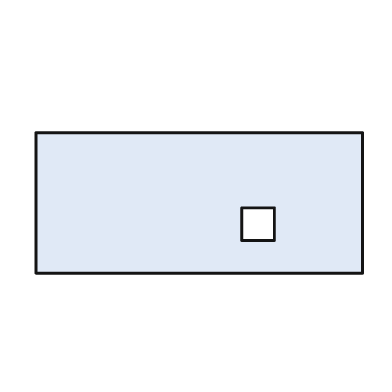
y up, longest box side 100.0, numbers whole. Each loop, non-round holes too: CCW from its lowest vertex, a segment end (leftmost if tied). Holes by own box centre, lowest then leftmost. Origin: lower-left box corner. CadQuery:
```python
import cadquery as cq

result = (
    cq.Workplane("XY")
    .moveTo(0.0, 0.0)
    .lineTo(100.0, 0.0)
    .lineTo(100.0, 43.0)
    .lineTo(0.0, 43.0)
    .close()
    .moveTo(63.0, 10.0)
    .lineTo(73.0, 10.0)
    .lineTo(73.0, 20.0)
    .lineTo(63.0, 20.0)
    .close()
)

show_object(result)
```